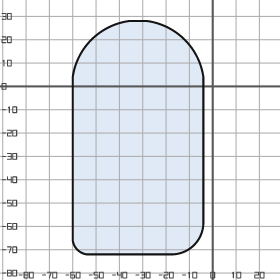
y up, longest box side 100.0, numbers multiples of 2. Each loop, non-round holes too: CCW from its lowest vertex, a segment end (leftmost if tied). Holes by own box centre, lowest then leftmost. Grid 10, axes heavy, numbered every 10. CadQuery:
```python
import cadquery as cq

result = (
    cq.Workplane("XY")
    .moveTo(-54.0, -72.0)
    .lineTo(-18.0, -72.0)
    .threePointArc((-8.0, -68.0), (-4.0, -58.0))
    .lineTo(-4.0, 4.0)
    .threePointArc((-12.0, 20.0), (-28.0, 28.0))
    .lineTo(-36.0, 28.0)
    .threePointArc((-52.0, 20.0), (-60.0, 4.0))
    .lineTo(-60.0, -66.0)
    .threePointArc((-58.0, -70.0), (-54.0, -72.0))
    .close()
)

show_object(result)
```